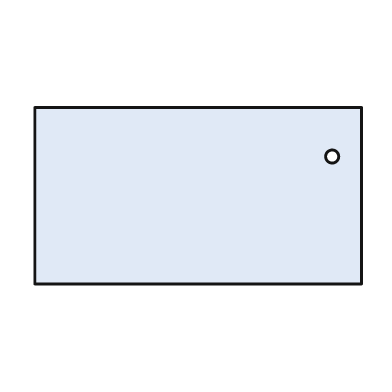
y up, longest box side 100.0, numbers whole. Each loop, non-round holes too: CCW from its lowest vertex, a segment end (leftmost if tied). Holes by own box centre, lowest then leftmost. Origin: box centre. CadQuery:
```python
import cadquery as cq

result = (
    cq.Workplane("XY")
    .moveTo(-50.0, -27.0)
    .lineTo(50.0, -27.0)
    .lineTo(50.0, 27.0)
    .lineTo(-50.0, 27.0)
    .close()
    .moveTo(41.0, 12.0)
    .circle(2.0)
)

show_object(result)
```